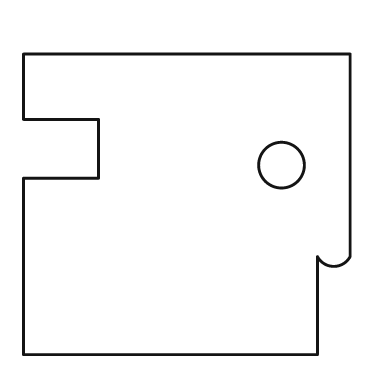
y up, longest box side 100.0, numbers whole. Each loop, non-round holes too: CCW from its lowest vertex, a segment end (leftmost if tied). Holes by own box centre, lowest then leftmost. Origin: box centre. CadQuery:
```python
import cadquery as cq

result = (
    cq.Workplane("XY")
    .moveTo(-50.0, -46.0)
    .lineTo(40.0, -46.0)
    .lineTo(40.0, -16.0)
    .threePointArc((45.0, -19.0), (50.0, -16.0))
    .lineTo(50.0, 46.0)
    .lineTo(-50.0, 46.0)
    .lineTo(-50.0, 26.0)
    .lineTo(-27.0, 26.0)
    .lineTo(-27.0, 8.0)
    .lineTo(-50.0, 8.0)
    .close()
    .moveTo(29.0, 12.0)
    .circle(7.0)
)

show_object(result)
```